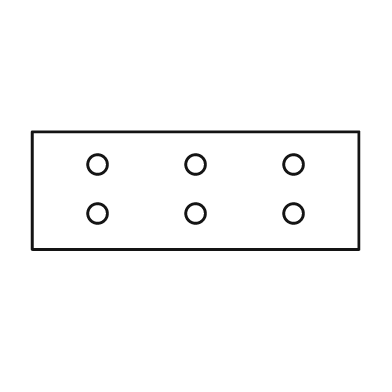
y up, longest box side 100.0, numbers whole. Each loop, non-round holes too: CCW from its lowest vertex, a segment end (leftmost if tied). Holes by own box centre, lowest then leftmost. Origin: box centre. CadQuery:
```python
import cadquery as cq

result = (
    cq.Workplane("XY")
    .moveTo(-50.0, -18.0)
    .lineTo(50.0, -18.0)
    .lineTo(50.0, 18.0)
    .lineTo(-50.0, 18.0)
    .close()
    .moveTo(-30.0, -7.0)
    .circle(3.0)
    .moveTo(0.0, -7.0)
    .circle(3.0)
    .moveTo(30.0, -7.0)
    .circle(3.0)
    .moveTo(-30.0, 8.0)
    .circle(3.0)
    .moveTo(0.0, 8.0)
    .circle(3.0)
    .moveTo(30.0, 8.0)
    .circle(3.0)
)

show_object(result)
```